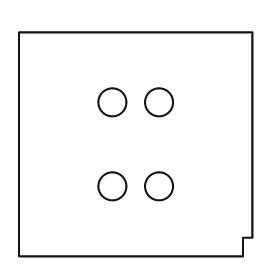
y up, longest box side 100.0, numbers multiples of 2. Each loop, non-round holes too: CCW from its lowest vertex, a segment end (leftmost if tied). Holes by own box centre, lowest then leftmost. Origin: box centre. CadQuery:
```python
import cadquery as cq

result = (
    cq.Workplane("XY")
    .moveTo(-50.0, -48.0)
    .lineTo(46.0, -48.0)
    .lineTo(46.0, -40.0)
    .lineTo(50.0, -40.0)
    .lineTo(50.0, 48.0)
    .lineTo(-50.0, 48.0)
    .close()
    .moveTo(-10.0, -18.0)
    .circle(6.0)
    .moveTo(10.0, -18.0)
    .circle(6.0)
    .moveTo(-10.0, 18.0)
    .circle(6.0)
    .moveTo(10.0, 18.0)
    .circle(6.0)
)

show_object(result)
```